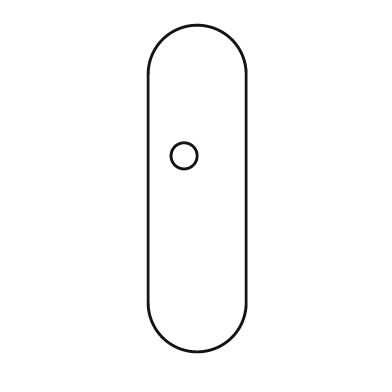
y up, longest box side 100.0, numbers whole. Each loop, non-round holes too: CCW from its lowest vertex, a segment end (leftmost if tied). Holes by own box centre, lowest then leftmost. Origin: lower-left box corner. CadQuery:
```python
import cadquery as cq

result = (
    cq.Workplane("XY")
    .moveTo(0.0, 15.0)
    .threePointArc((15.0, 0.0), (30.0, 15.0))
    .lineTo(30.0, 85.0)
    .threePointArc((15.0, 100.0), (0.0, 85.0))
    .close()
    .moveTo(11.0, 60.0)
    .circle(4.0)
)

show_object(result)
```